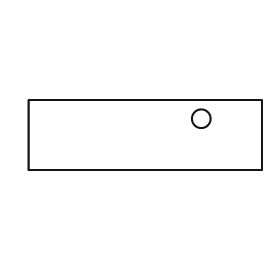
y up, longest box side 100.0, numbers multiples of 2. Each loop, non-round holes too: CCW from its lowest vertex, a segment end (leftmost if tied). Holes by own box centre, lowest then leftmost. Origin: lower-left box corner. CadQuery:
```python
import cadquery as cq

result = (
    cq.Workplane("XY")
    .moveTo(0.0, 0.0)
    .lineTo(100.0, 0.0)
    .lineTo(100.0, 30.0)
    .lineTo(0.0, 30.0)
    .close()
    .moveTo(74.0, 22.0)
    .circle(4.0)
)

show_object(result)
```